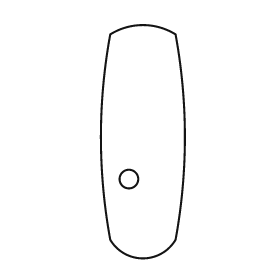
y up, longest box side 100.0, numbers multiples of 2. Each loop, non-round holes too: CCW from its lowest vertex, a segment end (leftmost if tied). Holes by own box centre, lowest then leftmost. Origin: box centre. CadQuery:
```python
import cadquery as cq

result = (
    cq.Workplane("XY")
    .moveTo(-14.0, -42.0)
    .threePointArc((0.0, -50.0), (14.0, -42.0))
    .threePointArc((18.0, 2.0), (14.0, 46.0))
    .threePointArc((0.0, 50.0), (-14.0, 46.0))
    .threePointArc((-18.0, 2.0), (-14.0, -42.0))
    .close()
    .moveTo(-6.0, -16.0)
    .circle(4.0)
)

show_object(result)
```